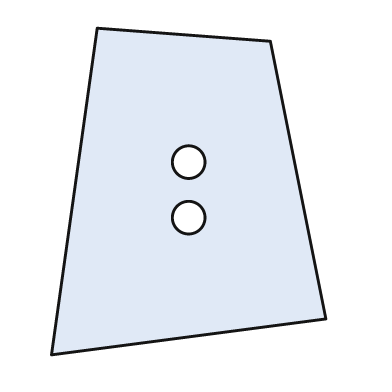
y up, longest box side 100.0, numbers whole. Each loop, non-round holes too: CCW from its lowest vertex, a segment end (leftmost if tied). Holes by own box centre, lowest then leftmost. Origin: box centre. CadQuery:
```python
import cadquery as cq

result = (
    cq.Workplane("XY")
    .moveTo(-42.0, -50.0)
    .lineTo(42.0, -39.0)
    .lineTo(25.0, 46.0)
    .lineTo(-28.0, 50.0)
    .close()
    .moveTo(0.0, -8.0)
    .circle(5.0)
    .moveTo(0.0, 9.0)
    .circle(5.0)
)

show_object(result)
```